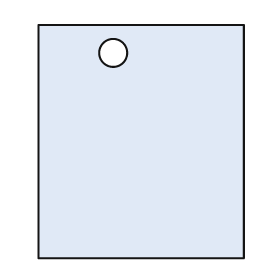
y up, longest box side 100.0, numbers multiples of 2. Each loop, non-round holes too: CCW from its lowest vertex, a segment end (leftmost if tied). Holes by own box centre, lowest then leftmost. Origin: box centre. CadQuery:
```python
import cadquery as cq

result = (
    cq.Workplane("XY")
    .moveTo(-44.0, -50.0)
    .lineTo(44.0, -50.0)
    .lineTo(44.0, 50.0)
    .lineTo(-44.0, 50.0)
    .close()
    .moveTo(-12.0, 38.0)
    .circle(6.0)
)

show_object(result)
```